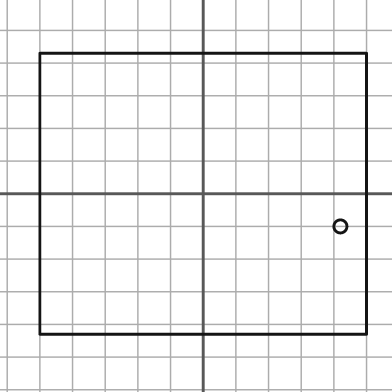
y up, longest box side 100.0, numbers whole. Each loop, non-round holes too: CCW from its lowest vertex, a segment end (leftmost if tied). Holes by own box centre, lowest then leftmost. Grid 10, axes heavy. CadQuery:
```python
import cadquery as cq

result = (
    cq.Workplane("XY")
    .moveTo(-50.0, -43.0)
    .lineTo(50.0, -43.0)
    .lineTo(50.0, 43.0)
    .lineTo(-50.0, 43.0)
    .close()
    .moveTo(42.0, -10.0)
    .circle(2.0)
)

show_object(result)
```